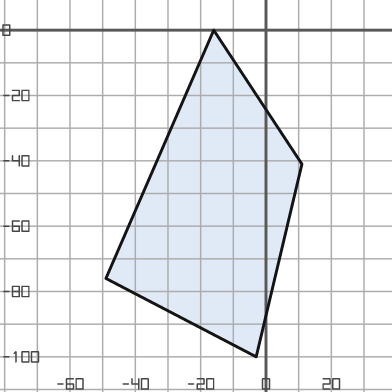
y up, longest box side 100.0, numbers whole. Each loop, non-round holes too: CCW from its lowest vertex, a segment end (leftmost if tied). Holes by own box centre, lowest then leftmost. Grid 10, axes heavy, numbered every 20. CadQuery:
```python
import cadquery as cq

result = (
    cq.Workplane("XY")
    .moveTo(-3.0, -100.0)
    .lineTo(11.0, -41.0)
    .lineTo(-16.0, 0.0)
    .lineTo(-49.0, -76.0)
    .close()
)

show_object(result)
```